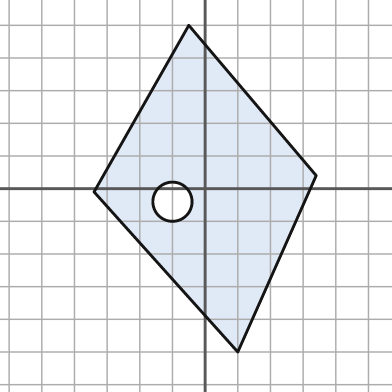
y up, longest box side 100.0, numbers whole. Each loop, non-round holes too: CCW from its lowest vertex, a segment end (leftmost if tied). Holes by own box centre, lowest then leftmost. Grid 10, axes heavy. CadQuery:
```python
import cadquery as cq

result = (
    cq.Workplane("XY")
    .moveTo(10.0, -50.0)
    .lineTo(34.0, 4.0)
    .lineTo(-5.0, 50.0)
    .lineTo(-34.0, -1.0)
    .close()
    .moveTo(-10.0, -4.0)
    .circle(6.0)
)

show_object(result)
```